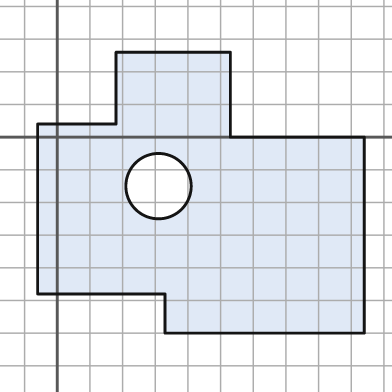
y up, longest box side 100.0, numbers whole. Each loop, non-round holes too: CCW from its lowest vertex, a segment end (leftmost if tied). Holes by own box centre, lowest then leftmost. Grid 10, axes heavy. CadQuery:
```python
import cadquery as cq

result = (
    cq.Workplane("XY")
    .moveTo(33.0, -60.0)
    .lineTo(94.0, -60.0)
    .lineTo(94.0, 0.0)
    .lineTo(53.0, 0.0)
    .lineTo(53.0, 26.0)
    .lineTo(18.0, 26.0)
    .lineTo(18.0, 4.0)
    .lineTo(-6.0, 4.0)
    .lineTo(-6.0, -48.0)
    .lineTo(33.0, -48.0)
    .close()
    .moveTo(31.0, -15.0)
    .circle(10.0)
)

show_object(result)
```